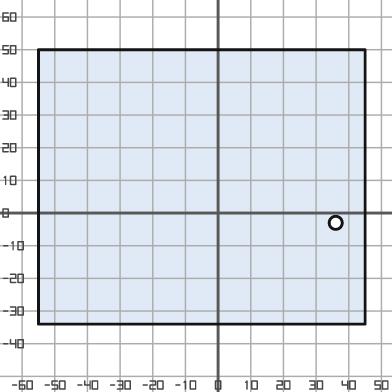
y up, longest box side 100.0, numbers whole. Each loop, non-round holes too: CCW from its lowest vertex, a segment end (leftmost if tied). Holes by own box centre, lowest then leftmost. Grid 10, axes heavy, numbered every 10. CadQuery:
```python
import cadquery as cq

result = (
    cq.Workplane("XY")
    .moveTo(-55.0, -34.0)
    .lineTo(45.0, -34.0)
    .lineTo(45.0, 50.0)
    .lineTo(-55.0, 50.0)
    .close()
    .moveTo(36.0, -3.0)
    .circle(2.0)
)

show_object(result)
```